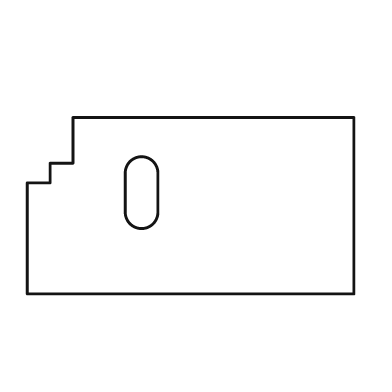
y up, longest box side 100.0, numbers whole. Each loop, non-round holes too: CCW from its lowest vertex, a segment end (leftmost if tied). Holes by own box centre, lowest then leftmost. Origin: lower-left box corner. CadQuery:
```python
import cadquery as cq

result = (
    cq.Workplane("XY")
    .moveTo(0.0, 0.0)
    .lineTo(100.0, 0.0)
    .lineTo(100.0, 54.0)
    .lineTo(14.0, 54.0)
    .lineTo(14.0, 40.0)
    .lineTo(7.0, 40.0)
    .lineTo(7.0, 34.0)
    .lineTo(0.0, 34.0)
    .close()
    .moveTo(30.0, 25.0)
    .threePointArc((35.0, 20.0), (40.0, 25.0))
    .lineTo(40.0, 37.0)
    .threePointArc((35.0, 42.0), (30.0, 37.0))
    .close()
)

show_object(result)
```